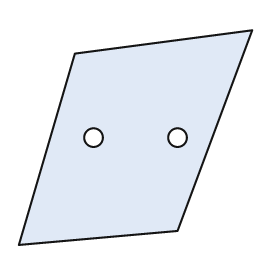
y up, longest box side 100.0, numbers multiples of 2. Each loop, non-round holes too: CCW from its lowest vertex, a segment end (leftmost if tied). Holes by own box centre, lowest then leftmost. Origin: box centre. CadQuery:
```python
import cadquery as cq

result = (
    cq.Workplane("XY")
    .moveTo(-50.0, -46.0)
    .lineTo(18.0, -40.0)
    .lineTo(50.0, 46.0)
    .lineTo(-26.0, 36.0)
    .close()
    .moveTo(-18.0, 0.0)
    .circle(4.0)
    .moveTo(18.0, 0.0)
    .circle(4.0)
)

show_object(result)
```